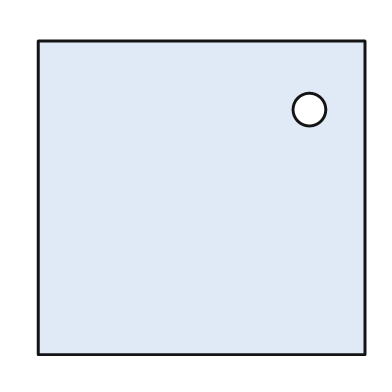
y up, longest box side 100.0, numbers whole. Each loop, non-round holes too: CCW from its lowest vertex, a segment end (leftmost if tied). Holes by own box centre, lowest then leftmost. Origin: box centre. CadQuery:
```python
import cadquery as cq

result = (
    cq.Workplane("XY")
    .moveTo(-50.0, -48.0)
    .lineTo(50.0, -48.0)
    .lineTo(50.0, 48.0)
    .lineTo(-50.0, 48.0)
    .close()
    .moveTo(33.0, 27.0)
    .circle(5.0)
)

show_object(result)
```